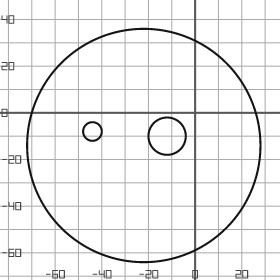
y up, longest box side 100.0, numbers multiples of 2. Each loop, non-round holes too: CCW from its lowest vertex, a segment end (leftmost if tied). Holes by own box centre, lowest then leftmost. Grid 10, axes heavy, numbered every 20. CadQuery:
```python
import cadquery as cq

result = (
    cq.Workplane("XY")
    .moveTo(-22.0, -14.0)
    .circle(50.0)
    .moveTo(-12.0, -10.0)
    .circle(8.0)
    .moveTo(-44.0, -8.0)
    .circle(4.0)
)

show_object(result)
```